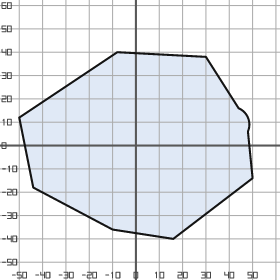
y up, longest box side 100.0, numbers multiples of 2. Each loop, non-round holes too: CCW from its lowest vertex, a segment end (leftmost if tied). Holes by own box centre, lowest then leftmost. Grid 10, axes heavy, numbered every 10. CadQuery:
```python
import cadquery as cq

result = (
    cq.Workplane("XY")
    .moveTo(16.0, -40.0)
    .lineTo(50.0, -14.0)
    .lineTo(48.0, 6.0)
    .threePointArc((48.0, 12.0), (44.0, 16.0))
    .lineTo(30.0, 38.0)
    .lineTo(-8.0, 40.0)
    .lineTo(-50.0, 12.0)
    .lineTo(-44.0, -18.0)
    .lineTo(-10.0, -36.0)
    .close()
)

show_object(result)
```